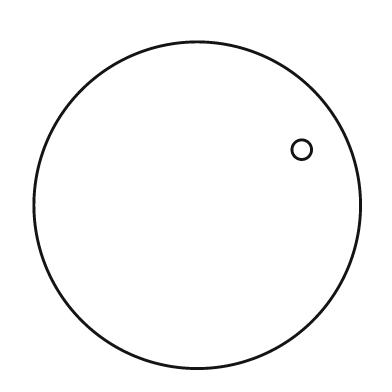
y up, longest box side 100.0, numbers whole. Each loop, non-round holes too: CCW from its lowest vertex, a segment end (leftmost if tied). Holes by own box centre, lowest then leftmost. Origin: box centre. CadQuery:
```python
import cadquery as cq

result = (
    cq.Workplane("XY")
    .moveTo(0.0, 0.0)
    .circle(50.0)
    .moveTo(32.0, 17.0)
    .circle(3.0)
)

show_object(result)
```